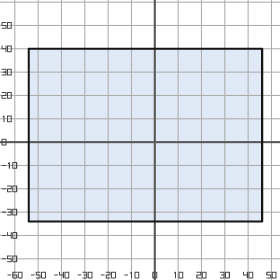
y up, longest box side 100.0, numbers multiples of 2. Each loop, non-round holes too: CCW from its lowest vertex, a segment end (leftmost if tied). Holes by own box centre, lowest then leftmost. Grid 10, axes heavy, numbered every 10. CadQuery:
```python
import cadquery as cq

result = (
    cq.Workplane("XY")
    .moveTo(-54.0, -34.0)
    .lineTo(46.0, -34.0)
    .lineTo(46.0, 40.0)
    .lineTo(-54.0, 40.0)
    .close()
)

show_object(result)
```